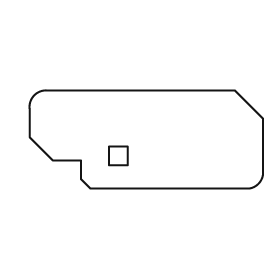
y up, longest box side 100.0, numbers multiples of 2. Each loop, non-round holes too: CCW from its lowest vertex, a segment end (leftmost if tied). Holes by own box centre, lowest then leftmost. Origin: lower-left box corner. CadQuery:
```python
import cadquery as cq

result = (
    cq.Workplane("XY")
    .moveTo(26.0, 0.0)
    .lineTo(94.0, 0.0)
    .threePointArc((98.0, 2.0), (100.0, 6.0))
    .lineTo(100.0, 30.0)
    .lineTo(88.0, 42.0)
    .lineTo(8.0, 42.0)
    .threePointArc((2.0, 40.0), (0.0, 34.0))
    .lineTo(0.0, 22.0)
    .lineTo(10.0, 12.0)
    .lineTo(22.0, 12.0)
    .lineTo(22.0, 4.0)
    .close()
    .moveTo(34.0, 10.0)
    .lineTo(42.0, 10.0)
    .lineTo(42.0, 18.0)
    .lineTo(34.0, 18.0)
    .close()
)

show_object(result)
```